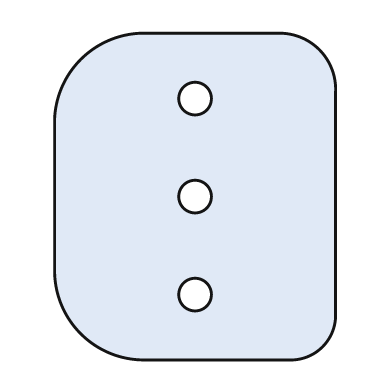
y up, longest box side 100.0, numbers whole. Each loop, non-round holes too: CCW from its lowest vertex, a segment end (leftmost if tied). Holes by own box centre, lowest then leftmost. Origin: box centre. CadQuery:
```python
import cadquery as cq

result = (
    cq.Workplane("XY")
    .moveTo(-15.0, -50.0)
    .lineTo(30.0, -50.0)
    .threePointArc((39.0, -46.0), (43.0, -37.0))
    .lineTo(43.0, 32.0)
    .threePointArc((38.0, 45.0), (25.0, 50.0))
    .lineTo(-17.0, 50.0)
    .threePointArc((-35.0, 42.0), (-43.0, 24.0))
    .lineTo(-43.0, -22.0)
    .threePointArc((-35.0, -42.0), (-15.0, -50.0))
    .close()
    .moveTo(0.0, -30.0)
    .circle(5.0)
    .moveTo(0.0, 0.0)
    .circle(5.0)
    .moveTo(0.0, 30.0)
    .circle(5.0)
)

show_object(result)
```